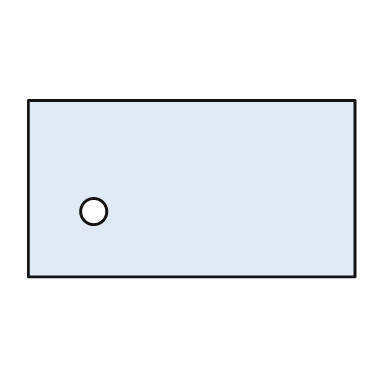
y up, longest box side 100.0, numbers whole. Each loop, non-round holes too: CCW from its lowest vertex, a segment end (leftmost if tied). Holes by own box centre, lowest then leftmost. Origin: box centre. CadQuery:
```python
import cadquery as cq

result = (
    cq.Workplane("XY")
    .moveTo(-50.0, -27.0)
    .lineTo(50.0, -27.0)
    .lineTo(50.0, 27.0)
    .lineTo(-50.0, 27.0)
    .close()
    .moveTo(-30.0, -7.0)
    .circle(4.0)
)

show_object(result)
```